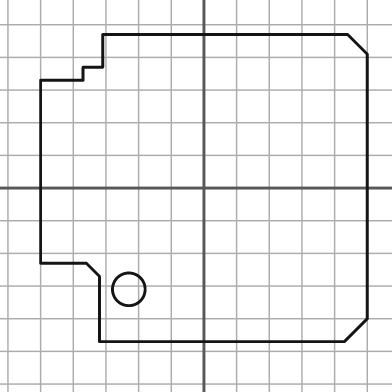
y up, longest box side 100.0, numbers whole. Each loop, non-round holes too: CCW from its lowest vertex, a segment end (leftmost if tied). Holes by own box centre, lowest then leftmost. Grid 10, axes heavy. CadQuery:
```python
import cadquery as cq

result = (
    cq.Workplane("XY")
    .moveTo(-32.0, -47.0)
    .lineTo(43.0, -47.0)
    .lineTo(50.0, -40.0)
    .lineTo(50.0, 41.0)
    .lineTo(44.0, 47.0)
    .lineTo(-31.0, 47.0)
    .lineTo(-31.0, 37.0)
    .lineTo(-37.0, 37.0)
    .lineTo(-37.0, 33.0)
    .lineTo(-50.0, 33.0)
    .lineTo(-50.0, -23.0)
    .lineTo(-36.0, -23.0)
    .lineTo(-32.0, -27.0)
    .close()
    .moveTo(-23.0, -31.0)
    .circle(5.0)
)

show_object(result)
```